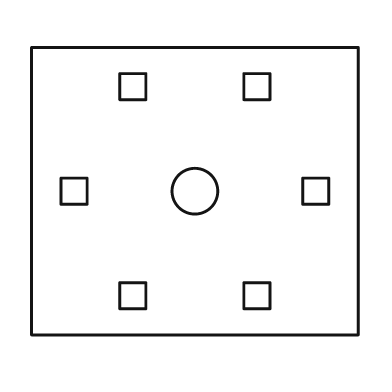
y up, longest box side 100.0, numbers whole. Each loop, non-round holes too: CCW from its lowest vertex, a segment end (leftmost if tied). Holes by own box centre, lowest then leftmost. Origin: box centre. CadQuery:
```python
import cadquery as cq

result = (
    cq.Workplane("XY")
    .moveTo(-50.0, -44.0)
    .lineTo(50.0, -44.0)
    .lineTo(50.0, 44.0)
    .lineTo(-50.0, 44.0)
    .close()
    .moveTo(-23.0, -36.0)
    .lineTo(-15.0, -36.0)
    .lineTo(-15.0, -28.0)
    .lineTo(-23.0, -28.0)
    .close()
    .moveTo(15.0, -36.0)
    .lineTo(23.0, -36.0)
    .lineTo(23.0, -28.0)
    .lineTo(15.0, -28.0)
    .close()
    .moveTo(-41.0, -4.0)
    .lineTo(-33.0, -4.0)
    .lineTo(-33.0, 4.0)
    .lineTo(-41.0, 4.0)
    .close()
    .moveTo(0.0, 0.0)
    .circle(7.0)
    .moveTo(33.0, -4.0)
    .lineTo(41.0, -4.0)
    .lineTo(41.0, 4.0)
    .lineTo(33.0, 4.0)
    .close()
    .moveTo(-23.0, 28.0)
    .lineTo(-15.0, 28.0)
    .lineTo(-15.0, 36.0)
    .lineTo(-23.0, 36.0)
    .close()
    .moveTo(15.0, 28.0)
    .lineTo(23.0, 28.0)
    .lineTo(23.0, 36.0)
    .lineTo(15.0, 36.0)
    .close()
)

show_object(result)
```